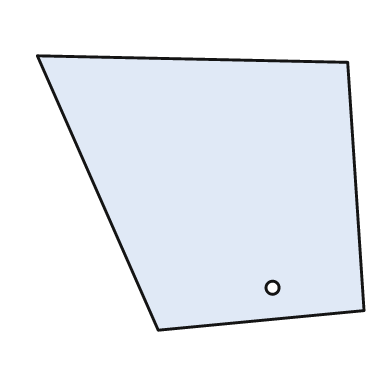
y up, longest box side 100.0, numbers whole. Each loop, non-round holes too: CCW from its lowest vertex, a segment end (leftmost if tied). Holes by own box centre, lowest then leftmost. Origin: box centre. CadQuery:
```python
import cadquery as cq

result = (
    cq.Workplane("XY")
    .moveTo(-13.0, -42.0)
    .lineTo(50.0, -36.0)
    .lineTo(45.0, 40.0)
    .lineTo(-50.0, 42.0)
    .close()
    .moveTo(22.0, -29.0)
    .circle(2.0)
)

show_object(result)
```